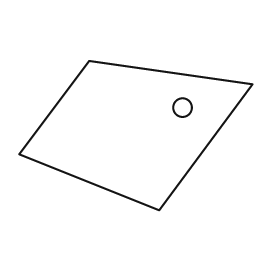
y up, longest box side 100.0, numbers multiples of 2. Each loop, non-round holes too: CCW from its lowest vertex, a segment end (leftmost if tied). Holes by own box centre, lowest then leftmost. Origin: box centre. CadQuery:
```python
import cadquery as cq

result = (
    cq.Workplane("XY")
    .moveTo(10.0, -32.0)
    .lineTo(50.0, 22.0)
    .lineTo(-20.0, 32.0)
    .lineTo(-50.0, -8.0)
    .close()
    .moveTo(20.0, 12.0)
    .circle(4.0)
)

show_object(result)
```